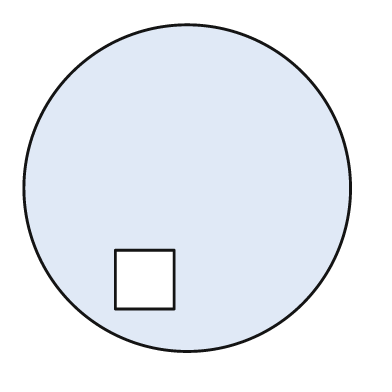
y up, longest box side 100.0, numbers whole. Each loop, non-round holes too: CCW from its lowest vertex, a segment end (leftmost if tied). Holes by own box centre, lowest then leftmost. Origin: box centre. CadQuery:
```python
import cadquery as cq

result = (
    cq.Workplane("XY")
    .moveTo(0.0, 0.0)
    .circle(50.0)
    .moveTo(-22.0, -37.0)
    .lineTo(-4.0, -37.0)
    .lineTo(-4.0, -19.0)
    .lineTo(-22.0, -19.0)
    .close()
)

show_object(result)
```